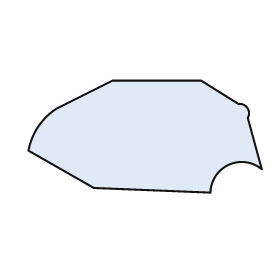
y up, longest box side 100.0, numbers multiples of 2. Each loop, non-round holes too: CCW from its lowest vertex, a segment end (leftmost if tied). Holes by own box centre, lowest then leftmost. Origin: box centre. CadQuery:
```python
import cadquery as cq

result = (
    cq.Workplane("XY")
    .moveTo(28.0, -24.0)
    .threePointArc((36.0, -12.0), (50.0, -14.0))
    .lineTo(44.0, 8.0)
    .threePointArc((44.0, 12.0), (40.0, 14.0))
    .lineTo(24.0, 24.0)
    .lineTo(-14.0, 24.0)
    .lineTo(-38.0, 12.0)
    .threePointArc((-46.0, 4.0), (-50.0, -6.0))
    .lineTo(-22.0, -22.0)
    .close()
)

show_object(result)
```